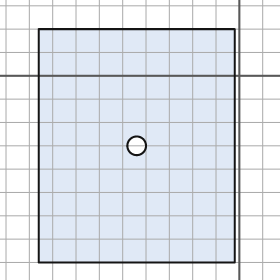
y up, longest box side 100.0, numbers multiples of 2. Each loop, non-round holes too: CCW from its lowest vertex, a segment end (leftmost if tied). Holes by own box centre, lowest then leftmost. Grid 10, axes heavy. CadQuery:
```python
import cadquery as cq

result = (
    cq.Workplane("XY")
    .moveTo(-86.0, -80.0)
    .lineTo(-2.0, -80.0)
    .lineTo(-2.0, 20.0)
    .lineTo(-86.0, 20.0)
    .close()
    .moveTo(-44.0, -30.0)
    .circle(4.0)
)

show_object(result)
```